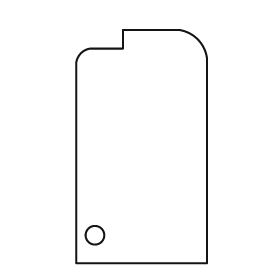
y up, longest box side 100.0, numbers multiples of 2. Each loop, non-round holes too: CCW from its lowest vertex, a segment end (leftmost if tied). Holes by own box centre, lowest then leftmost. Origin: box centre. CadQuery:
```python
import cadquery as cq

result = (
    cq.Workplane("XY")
    .moveTo(-28.0, -50.0)
    .lineTo(28.0, -50.0)
    .lineTo(28.0, 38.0)
    .threePointArc((24.0, 46.0), (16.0, 50.0))
    .lineTo(-8.0, 50.0)
    .lineTo(-8.0, 42.0)
    .lineTo(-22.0, 42.0)
    .threePointArc((-26.0, 40.0), (-28.0, 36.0))
    .close()
    .moveTo(-20.0, -38.0)
    .circle(4.0)
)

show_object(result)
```